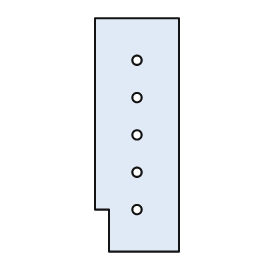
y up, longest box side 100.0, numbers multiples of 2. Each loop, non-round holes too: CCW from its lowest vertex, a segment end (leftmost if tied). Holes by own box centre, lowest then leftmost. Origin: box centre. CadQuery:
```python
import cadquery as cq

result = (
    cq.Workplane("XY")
    .moveTo(-12.0, -50.0)
    .lineTo(18.0, -50.0)
    .lineTo(18.0, 50.0)
    .lineTo(-18.0, 50.0)
    .lineTo(-18.0, -32.0)
    .lineTo(-12.0, -32.0)
    .close()
    .moveTo(0.0, -32.0)
    .circle(2.0)
    .moveTo(0.0, -16.0)
    .circle(2.0)
    .moveTo(0.0, 0.0)
    .circle(2.0)
    .moveTo(0.0, 16.0)
    .circle(2.0)
    .moveTo(0.0, 32.0)
    .circle(2.0)
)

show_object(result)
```